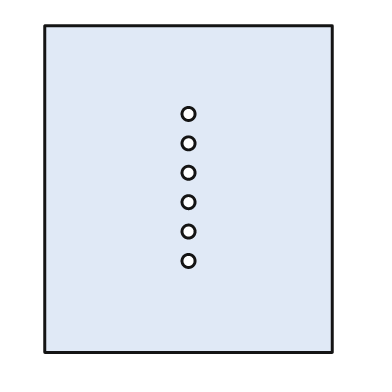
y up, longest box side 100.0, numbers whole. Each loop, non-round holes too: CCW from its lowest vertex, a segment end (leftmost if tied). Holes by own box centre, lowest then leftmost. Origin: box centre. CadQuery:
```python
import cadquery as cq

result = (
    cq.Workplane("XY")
    .moveTo(-44.0, -50.0)
    .lineTo(44.0, -50.0)
    .lineTo(44.0, 50.0)
    .lineTo(-44.0, 50.0)
    .close()
    .moveTo(0.0, -22.0)
    .circle(2.0)
    .moveTo(0.0, -13.0)
    .circle(2.0)
    .moveTo(0.0, -4.0)
    .circle(2.0)
    .moveTo(0.0, 5.0)
    .circle(2.0)
    .moveTo(0.0, 14.0)
    .circle(2.0)
    .moveTo(0.0, 23.0)
    .circle(2.0)
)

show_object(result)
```